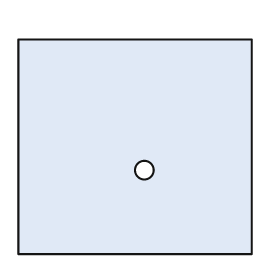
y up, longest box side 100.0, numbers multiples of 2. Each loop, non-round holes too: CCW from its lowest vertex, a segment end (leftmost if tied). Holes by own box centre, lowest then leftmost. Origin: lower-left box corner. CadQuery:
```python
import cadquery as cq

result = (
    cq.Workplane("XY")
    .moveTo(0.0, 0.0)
    .lineTo(100.0, 0.0)
    .lineTo(100.0, 92.0)
    .lineTo(0.0, 92.0)
    .close()
    .moveTo(54.0, 36.0)
    .circle(4.0)
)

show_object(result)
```